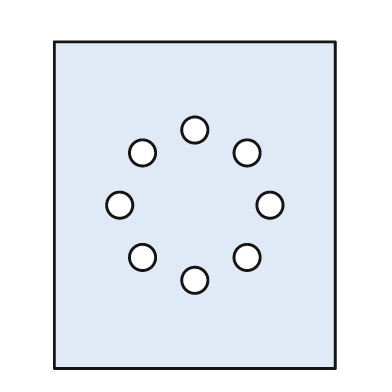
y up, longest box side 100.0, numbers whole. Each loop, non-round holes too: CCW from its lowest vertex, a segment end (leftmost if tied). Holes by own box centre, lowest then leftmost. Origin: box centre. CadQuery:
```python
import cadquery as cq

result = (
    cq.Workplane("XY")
    .moveTo(-43.0, -50.0)
    .lineTo(43.0, -50.0)
    .lineTo(43.0, 50.0)
    .lineTo(-43.0, 50.0)
    .close()
    .moveTo(0.0, -23.0)
    .circle(4.0)
    .moveTo(-16.0, -16.0)
    .circle(4.0)
    .moveTo(16.0, -16.0)
    .circle(4.0)
    .moveTo(-23.0, 0.0)
    .circle(4.0)
    .moveTo(23.0, 0.0)
    .circle(4.0)
    .moveTo(-16.0, 16.0)
    .circle(4.0)
    .moveTo(16.0, 16.0)
    .circle(4.0)
    .moveTo(0.0, 23.0)
    .circle(4.0)
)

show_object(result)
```